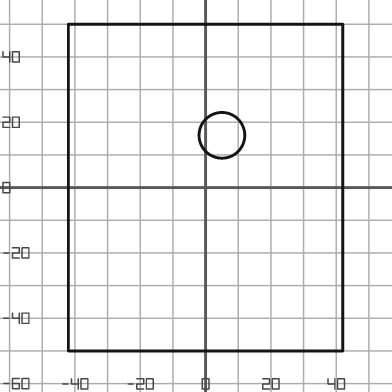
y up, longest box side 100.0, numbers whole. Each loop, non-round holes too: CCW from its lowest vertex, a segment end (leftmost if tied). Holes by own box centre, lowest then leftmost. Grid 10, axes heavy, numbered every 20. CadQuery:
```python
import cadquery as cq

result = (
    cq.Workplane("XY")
    .moveTo(-42.0, -50.0)
    .lineTo(42.0, -50.0)
    .lineTo(42.0, 50.0)
    .lineTo(-42.0, 50.0)
    .close()
    .moveTo(5.0, 16.0)
    .circle(7.0)
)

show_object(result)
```